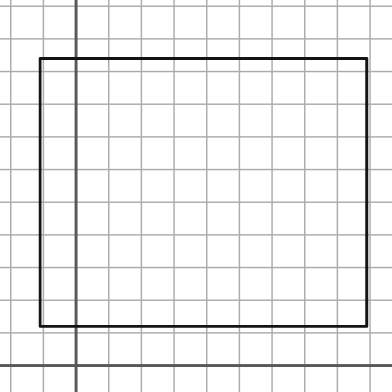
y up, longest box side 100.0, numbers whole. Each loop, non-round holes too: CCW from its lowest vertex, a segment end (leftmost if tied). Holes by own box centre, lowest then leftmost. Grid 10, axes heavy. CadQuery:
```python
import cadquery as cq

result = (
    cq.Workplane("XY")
    .moveTo(-11.0, 12.0)
    .lineTo(89.0, 12.0)
    .lineTo(89.0, 94.0)
    .lineTo(-11.0, 94.0)
    .close()
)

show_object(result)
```